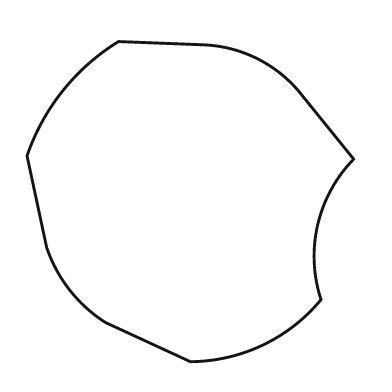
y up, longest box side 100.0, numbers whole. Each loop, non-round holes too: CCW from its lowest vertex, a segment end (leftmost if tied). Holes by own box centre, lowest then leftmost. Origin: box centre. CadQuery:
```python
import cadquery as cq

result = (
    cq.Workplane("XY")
    .moveTo(0.0, -49.0)
    .threePointArc((22.0, -44.0), (40.0, -30.0))
    .threePointArc((39.0, -7.0), (50.0, 13.0))
    .lineTo(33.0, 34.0)
    .threePointArc((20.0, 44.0), (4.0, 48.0))
    .lineTo(-22.0, 49.0)
    .threePointArc((-39.0, 34.0), (-50.0, 14.0))
    .lineTo(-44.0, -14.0)
    .threePointArc((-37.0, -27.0), (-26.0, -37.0))
    .close()
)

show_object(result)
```